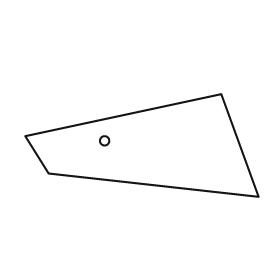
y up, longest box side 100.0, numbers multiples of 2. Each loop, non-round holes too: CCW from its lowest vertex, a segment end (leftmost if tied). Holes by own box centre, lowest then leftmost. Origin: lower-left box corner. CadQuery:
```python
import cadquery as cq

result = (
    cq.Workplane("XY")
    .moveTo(100.0, 0.0)
    .lineTo(84.0, 44.0)
    .lineTo(0.0, 26.0)
    .lineTo(10.0, 10.0)
    .close()
    .moveTo(34.0, 24.0)
    .circle(2.0)
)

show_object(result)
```